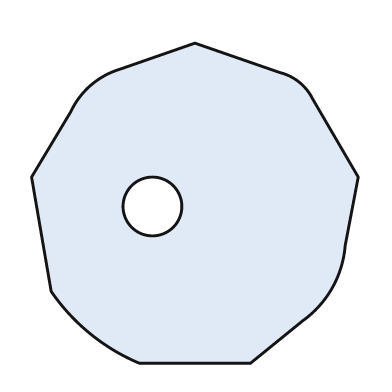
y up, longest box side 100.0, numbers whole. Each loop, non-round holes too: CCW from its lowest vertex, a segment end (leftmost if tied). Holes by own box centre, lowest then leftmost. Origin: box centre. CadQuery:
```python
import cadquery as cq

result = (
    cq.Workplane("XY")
    .moveTo(-17.0, -49.0)
    .lineTo(17.0, -49.0)
    .lineTo(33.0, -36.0)
    .threePointArc((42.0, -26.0), (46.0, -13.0))
    .lineTo(50.0, 8.0)
    .lineTo(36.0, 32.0)
    .threePointArc((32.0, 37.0), (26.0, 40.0))
    .lineTo(0.0, 49.0)
    .lineTo(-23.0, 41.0)
    .threePointArc((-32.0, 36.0), (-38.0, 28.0))
    .lineTo(-50.0, 8.0)
    .lineTo(-44.0, -27.0)
    .threePointArc((-32.0, -40.0), (-17.0, -49.0))
    .close()
    .moveTo(-13.0, -1.0)
    .circle(9.0)
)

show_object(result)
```